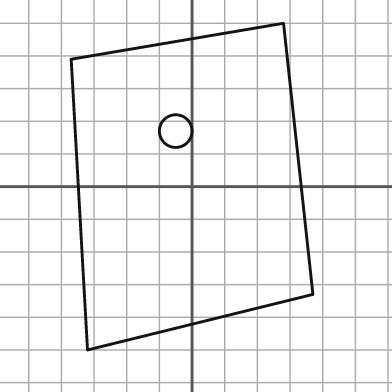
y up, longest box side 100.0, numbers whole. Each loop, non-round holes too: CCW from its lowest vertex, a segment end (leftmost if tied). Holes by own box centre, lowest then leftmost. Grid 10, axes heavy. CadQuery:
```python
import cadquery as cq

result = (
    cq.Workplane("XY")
    .moveTo(-32.0, -50.0)
    .lineTo(37.0, -33.0)
    .lineTo(28.0, 50.0)
    .lineTo(-37.0, 39.0)
    .close()
    .moveTo(-5.0, 17.0)
    .circle(5.0)
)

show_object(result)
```